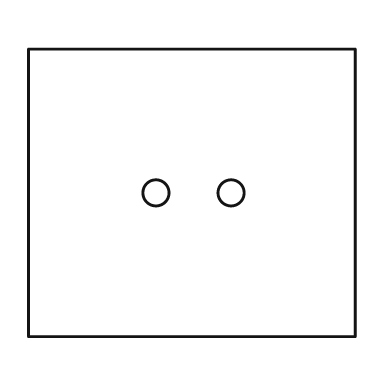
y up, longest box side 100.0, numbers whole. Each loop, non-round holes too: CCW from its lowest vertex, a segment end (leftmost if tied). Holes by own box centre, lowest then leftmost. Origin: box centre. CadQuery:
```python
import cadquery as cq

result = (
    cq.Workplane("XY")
    .moveTo(-50.0, -44.0)
    .lineTo(50.0, -44.0)
    .lineTo(50.0, 44.0)
    .lineTo(-50.0, 44.0)
    .close()
    .moveTo(-11.0, 0.0)
    .circle(4.0)
    .moveTo(12.0, 0.0)
    .circle(4.0)
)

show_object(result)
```